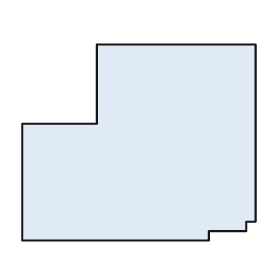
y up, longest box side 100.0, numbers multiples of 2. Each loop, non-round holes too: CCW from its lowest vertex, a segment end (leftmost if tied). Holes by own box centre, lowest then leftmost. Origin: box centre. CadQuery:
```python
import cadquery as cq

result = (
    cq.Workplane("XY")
    .moveTo(-50.0, -42.0)
    .lineTo(30.0, -42.0)
    .lineTo(30.0, -38.0)
    .lineTo(46.0, -38.0)
    .lineTo(46.0, -34.0)
    .lineTo(50.0, -34.0)
    .lineTo(50.0, 42.0)
    .lineTo(-18.0, 42.0)
    .lineTo(-18.0, 8.0)
    .lineTo(-50.0, 8.0)
    .close()
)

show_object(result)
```